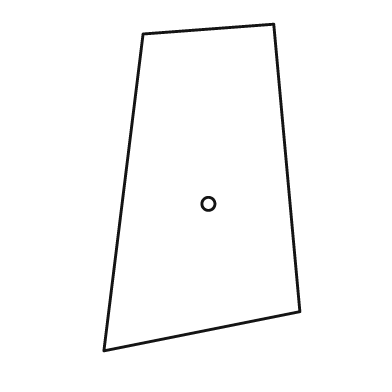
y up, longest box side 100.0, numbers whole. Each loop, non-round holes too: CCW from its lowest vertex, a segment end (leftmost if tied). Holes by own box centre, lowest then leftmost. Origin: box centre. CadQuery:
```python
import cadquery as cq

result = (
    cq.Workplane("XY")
    .moveTo(-30.0, -50.0)
    .lineTo(30.0, -38.0)
    .lineTo(22.0, 50.0)
    .lineTo(-18.0, 47.0)
    .close()
    .moveTo(2.0, -5.0)
    .circle(2.0)
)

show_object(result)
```